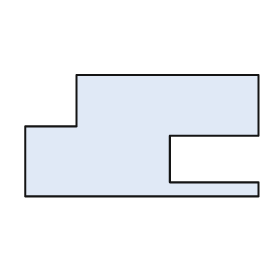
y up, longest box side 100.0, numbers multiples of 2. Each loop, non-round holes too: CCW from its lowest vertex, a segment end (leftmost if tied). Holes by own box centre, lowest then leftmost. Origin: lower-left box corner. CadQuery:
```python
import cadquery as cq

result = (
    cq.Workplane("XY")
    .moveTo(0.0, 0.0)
    .lineTo(100.0, 0.0)
    .lineTo(100.0, 6.0)
    .lineTo(62.0, 6.0)
    .lineTo(62.0, 26.0)
    .lineTo(100.0, 26.0)
    .lineTo(100.0, 52.0)
    .lineTo(22.0, 52.0)
    .lineTo(22.0, 30.0)
    .lineTo(0.0, 30.0)
    .close()
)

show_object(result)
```